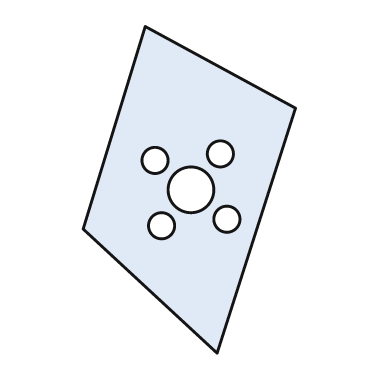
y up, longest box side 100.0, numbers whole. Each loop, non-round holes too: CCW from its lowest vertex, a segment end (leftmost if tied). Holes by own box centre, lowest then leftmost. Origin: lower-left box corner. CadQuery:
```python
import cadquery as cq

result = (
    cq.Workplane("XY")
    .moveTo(41.0, 0.0)
    .lineTo(65.0, 75.0)
    .lineTo(19.0, 100.0)
    .lineTo(0.0, 38.0)
    .close()
    .moveTo(24.0, 39.0)
    .circle(4.0)
    .moveTo(44.0, 41.0)
    .circle(4.0)
    .moveTo(33.0, 50.0)
    .circle(7.0)
    .moveTo(22.0, 59.0)
    .circle(4.0)
    .moveTo(42.0, 61.0)
    .circle(4.0)
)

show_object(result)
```